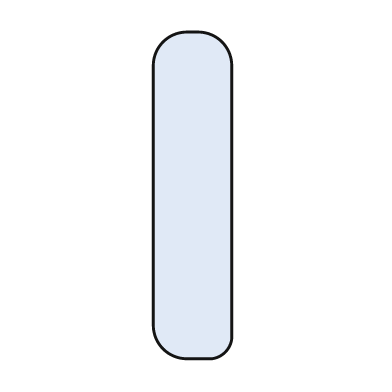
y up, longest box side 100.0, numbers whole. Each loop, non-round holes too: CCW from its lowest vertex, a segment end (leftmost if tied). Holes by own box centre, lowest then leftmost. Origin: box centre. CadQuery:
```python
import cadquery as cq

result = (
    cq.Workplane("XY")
    .moveTo(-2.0, -50.0)
    .lineTo(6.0, -50.0)
    .threePointArc((10.0, -48.0), (12.0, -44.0))
    .lineTo(12.0, 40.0)
    .threePointArc((9.0, 47.0), (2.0, 50.0))
    .lineTo(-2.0, 50.0)
    .threePointArc((-9.0, 47.0), (-12.0, 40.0))
    .lineTo(-12.0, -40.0)
    .threePointArc((-9.0, -47.0), (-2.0, -50.0))
    .close()
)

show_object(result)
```